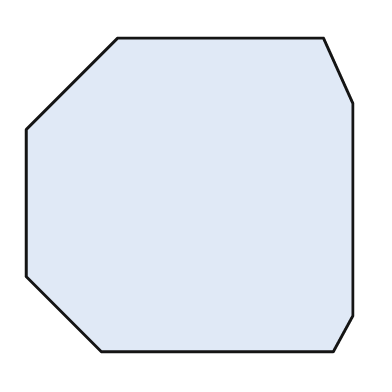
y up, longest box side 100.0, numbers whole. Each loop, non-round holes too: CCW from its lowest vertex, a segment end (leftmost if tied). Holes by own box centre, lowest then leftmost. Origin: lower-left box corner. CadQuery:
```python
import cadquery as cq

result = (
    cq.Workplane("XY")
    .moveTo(23.0, 0.0)
    .lineTo(94.0, 0.0)
    .lineTo(100.0, 11.0)
    .lineTo(100.0, 76.0)
    .lineTo(91.0, 96.0)
    .lineTo(28.0, 96.0)
    .lineTo(0.0, 68.0)
    .lineTo(0.0, 23.0)
    .close()
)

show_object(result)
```